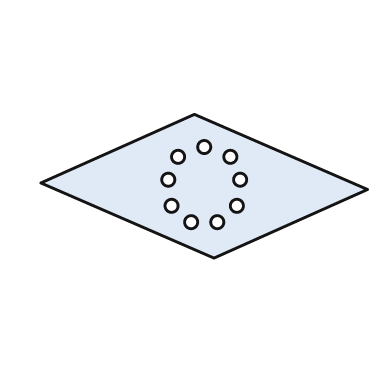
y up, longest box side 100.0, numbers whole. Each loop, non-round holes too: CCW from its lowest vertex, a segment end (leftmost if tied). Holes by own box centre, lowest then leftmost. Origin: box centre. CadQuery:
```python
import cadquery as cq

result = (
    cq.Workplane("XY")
    .moveTo(3.0, -22.0)
    .lineTo(50.0, -1.0)
    .lineTo(-3.0, 22.0)
    .lineTo(-50.0, 1.0)
    .close()
    .moveTo(-4.0, -11.0)
    .circle(2.0)
    .moveTo(4.0, -11.0)
    .circle(2.0)
    .moveTo(-10.0, -6.0)
    .circle(2.0)
    .moveTo(10.0, -6.0)
    .circle(2.0)
    .moveTo(-11.0, 2.0)
    .circle(2.0)
    .moveTo(11.0, 2.0)
    .circle(2.0)
    .moveTo(-8.0, 9.0)
    .circle(2.0)
    .moveTo(8.0, 9.0)
    .circle(2.0)
    .moveTo(0.0, 12.0)
    .circle(2.0)
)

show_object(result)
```